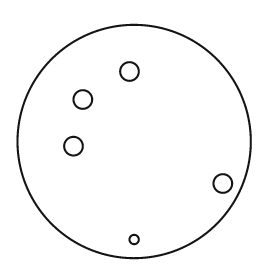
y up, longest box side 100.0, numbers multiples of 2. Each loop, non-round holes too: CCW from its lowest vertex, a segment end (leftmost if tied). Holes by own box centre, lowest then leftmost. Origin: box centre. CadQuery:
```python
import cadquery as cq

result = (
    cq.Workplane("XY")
    .moveTo(0.0, 0.0)
    .circle(50.0)
    .moveTo(0.0, -42.0)
    .circle(2.0)
    .moveTo(38.0, -18.0)
    .circle(4.0)
    .moveTo(-26.0, -2.0)
    .circle(4.0)
    .moveTo(-22.0, 18.0)
    .circle(4.0)
    .moveTo(-2.0, 30.0)
    .circle(4.0)
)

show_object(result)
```